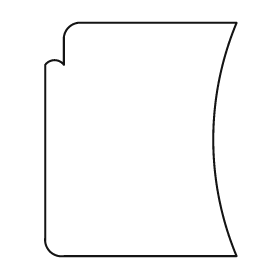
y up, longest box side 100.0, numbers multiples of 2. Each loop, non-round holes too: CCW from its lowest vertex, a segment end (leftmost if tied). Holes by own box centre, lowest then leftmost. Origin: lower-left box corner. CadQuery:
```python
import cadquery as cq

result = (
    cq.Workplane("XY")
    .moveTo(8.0, 0.0)
    .lineTo(82.0, 0.0)
    .threePointArc((72.0, 50.0), (82.0, 100.0))
    .lineTo(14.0, 100.0)
    .threePointArc((10.0, 98.0), (8.0, 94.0))
    .lineTo(8.0, 82.0)
    .threePointArc((4.0, 84.0), (0.0, 82.0))
    .lineTo(0.0, 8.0)
    .threePointArc((2.0, 2.0), (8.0, 0.0))
    .close()
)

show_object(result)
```